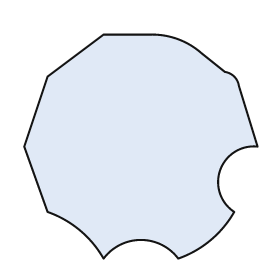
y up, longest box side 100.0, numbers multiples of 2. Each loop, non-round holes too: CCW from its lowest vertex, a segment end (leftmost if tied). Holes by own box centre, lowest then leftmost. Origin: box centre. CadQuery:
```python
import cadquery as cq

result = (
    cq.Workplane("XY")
    .moveTo(-16.0, -48.0)
    .threePointArc((0.0, -40.0), (16.0, -48.0))
    .threePointArc((30.0, -40.0), (40.0, -28.0))
    .threePointArc((34.0, -10.0), (50.0, 0.0))
    .lineTo(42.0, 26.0)
    .threePointArc((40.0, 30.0), (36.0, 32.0))
    .lineTo(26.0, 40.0)
    .threePointArc((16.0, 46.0), (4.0, 48.0))
    .lineTo(-16.0, 48.0)
    .lineTo(-40.0, 30.0)
    .lineTo(-50.0, 0.0)
    .lineTo(-40.0, -28.0)
    .threePointArc((-26.0, -36.0), (-16.0, -48.0))
    .close()
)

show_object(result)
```